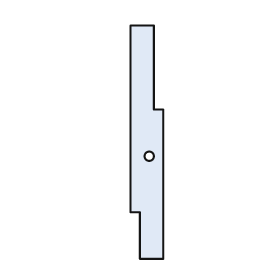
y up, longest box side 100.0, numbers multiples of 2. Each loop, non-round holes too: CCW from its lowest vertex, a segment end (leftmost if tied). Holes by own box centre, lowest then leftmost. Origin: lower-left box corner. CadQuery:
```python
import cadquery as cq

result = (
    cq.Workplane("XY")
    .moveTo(4.0, 0.0)
    .lineTo(14.0, 0.0)
    .lineTo(14.0, 64.0)
    .lineTo(10.0, 64.0)
    .lineTo(10.0, 100.0)
    .lineTo(0.0, 100.0)
    .lineTo(0.0, 20.0)
    .lineTo(4.0, 20.0)
    .close()
    .moveTo(8.0, 44.0)
    .circle(2.0)
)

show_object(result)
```